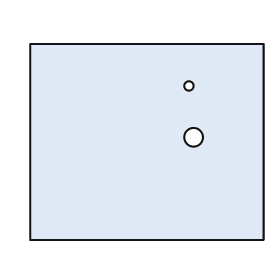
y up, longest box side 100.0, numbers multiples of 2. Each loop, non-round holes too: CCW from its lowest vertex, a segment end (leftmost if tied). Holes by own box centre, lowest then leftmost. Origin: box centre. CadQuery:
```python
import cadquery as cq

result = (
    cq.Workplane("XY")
    .moveTo(-50.0, -42.0)
    .lineTo(50.0, -42.0)
    .lineTo(50.0, 42.0)
    .lineTo(-50.0, 42.0)
    .close()
    .moveTo(20.0, 2.0)
    .circle(4.0)
    .moveTo(18.0, 24.0)
    .circle(2.0)
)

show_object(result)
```